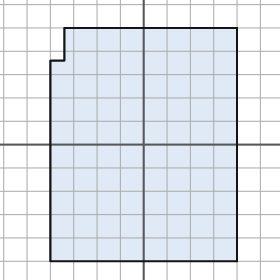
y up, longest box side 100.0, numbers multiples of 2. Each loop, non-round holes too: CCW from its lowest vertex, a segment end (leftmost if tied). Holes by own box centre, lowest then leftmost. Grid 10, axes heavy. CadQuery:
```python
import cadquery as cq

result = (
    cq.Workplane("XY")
    .moveTo(-40.0, -50.0)
    .lineTo(40.0, -50.0)
    .lineTo(40.0, 50.0)
    .lineTo(-34.0, 50.0)
    .lineTo(-34.0, 36.0)
    .lineTo(-40.0, 36.0)
    .close()
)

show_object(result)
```